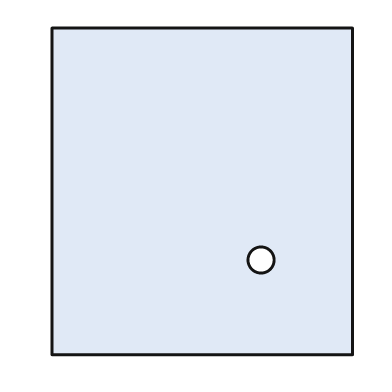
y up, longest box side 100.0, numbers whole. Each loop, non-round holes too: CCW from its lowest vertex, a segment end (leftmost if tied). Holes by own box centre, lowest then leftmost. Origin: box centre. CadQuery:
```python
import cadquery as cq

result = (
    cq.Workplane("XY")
    .moveTo(-46.0, -50.0)
    .lineTo(46.0, -50.0)
    .lineTo(46.0, 50.0)
    .lineTo(-46.0, 50.0)
    .close()
    .moveTo(18.0, -21.0)
    .circle(4.0)
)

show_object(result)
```